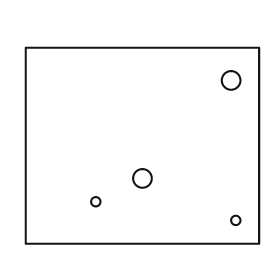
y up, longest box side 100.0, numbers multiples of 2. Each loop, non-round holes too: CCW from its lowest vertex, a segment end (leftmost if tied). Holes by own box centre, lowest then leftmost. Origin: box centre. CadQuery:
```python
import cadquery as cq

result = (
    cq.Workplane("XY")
    .moveTo(-50.0, -42.0)
    .lineTo(50.0, -42.0)
    .lineTo(50.0, 42.0)
    .lineTo(-50.0, 42.0)
    .close()
    .moveTo(40.0, -32.0)
    .circle(2.0)
    .moveTo(-20.0, -24.0)
    .circle(2.0)
    .moveTo(0.0, -14.0)
    .circle(4.0)
    .moveTo(38.0, 28.0)
    .circle(4.0)
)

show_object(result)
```